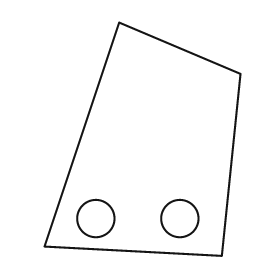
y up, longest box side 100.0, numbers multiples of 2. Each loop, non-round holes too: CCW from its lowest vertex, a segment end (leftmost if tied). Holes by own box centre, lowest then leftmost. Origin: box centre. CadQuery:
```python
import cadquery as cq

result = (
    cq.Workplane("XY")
    .moveTo(34.0, -50.0)
    .lineTo(42.0, 28.0)
    .lineTo(-10.0, 50.0)
    .lineTo(-42.0, -46.0)
    .close()
    .moveTo(-20.0, -34.0)
    .circle(8.0)
    .moveTo(16.0, -34.0)
    .circle(8.0)
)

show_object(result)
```